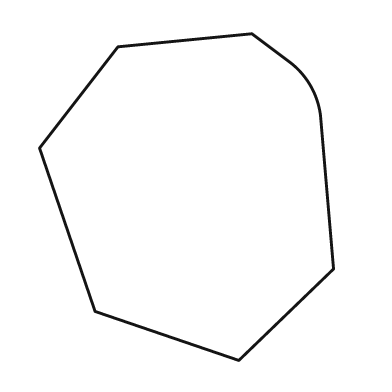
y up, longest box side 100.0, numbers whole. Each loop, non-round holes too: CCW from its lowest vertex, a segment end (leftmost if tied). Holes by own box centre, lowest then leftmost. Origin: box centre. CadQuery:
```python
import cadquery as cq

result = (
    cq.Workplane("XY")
    .moveTo(16.0, -50.0)
    .lineTo(45.0, -22.0)
    .lineTo(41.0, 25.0)
    .threePointArc((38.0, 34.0), (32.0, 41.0))
    .lineTo(20.0, 50.0)
    .lineTo(-21.0, 46.0)
    .lineTo(-45.0, 15.0)
    .lineTo(-28.0, -35.0)
    .close()
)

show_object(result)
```